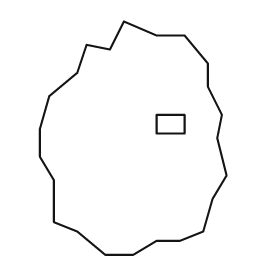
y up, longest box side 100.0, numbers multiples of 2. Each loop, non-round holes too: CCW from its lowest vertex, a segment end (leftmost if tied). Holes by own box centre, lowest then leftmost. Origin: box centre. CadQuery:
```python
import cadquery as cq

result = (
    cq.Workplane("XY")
    .moveTo(-12.0, -50.0)
    .lineTo(0.0, -50.0)
    .lineTo(10.0, -44.0)
    .lineTo(20.0, -44.0)
    .lineTo(30.0, -40.0)
    .lineTo(34.0, -26.0)
    .lineTo(40.0, -16.0)
    .lineTo(36.0, 0.0)
    .lineTo(38.0, 10.0)
    .lineTo(32.0, 22.0)
    .lineTo(32.0, 32.0)
    .lineTo(22.0, 44.0)
    .lineTo(10.0, 44.0)
    .lineTo(-4.0, 50.0)
    .lineTo(-10.0, 38.0)
    .lineTo(-20.0, 40.0)
    .lineTo(-24.0, 28.0)
    .lineTo(-36.0, 18.0)
    .lineTo(-40.0, 4.0)
    .lineTo(-40.0, -8.0)
    .lineTo(-34.0, -18.0)
    .lineTo(-34.0, -36.0)
    .lineTo(-24.0, -40.0)
    .close()
    .moveTo(10.0, 2.0)
    .lineTo(22.0, 2.0)
    .lineTo(22.0, 10.0)
    .lineTo(10.0, 10.0)
    .close()
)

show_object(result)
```